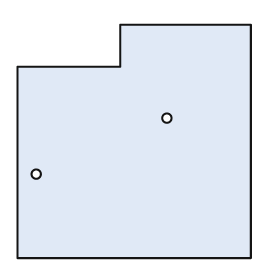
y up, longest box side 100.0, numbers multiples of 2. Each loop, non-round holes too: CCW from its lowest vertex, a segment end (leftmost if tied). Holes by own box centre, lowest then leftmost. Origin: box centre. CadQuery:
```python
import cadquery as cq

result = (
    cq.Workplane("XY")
    .moveTo(-50.0, -50.0)
    .lineTo(50.0, -50.0)
    .lineTo(50.0, 50.0)
    .lineTo(-6.0, 50.0)
    .lineTo(-6.0, 32.0)
    .lineTo(-50.0, 32.0)
    .close()
    .moveTo(-42.0, -14.0)
    .circle(2.0)
    .moveTo(14.0, 10.0)
    .circle(2.0)
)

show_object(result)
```